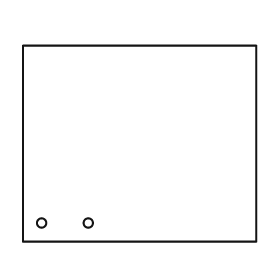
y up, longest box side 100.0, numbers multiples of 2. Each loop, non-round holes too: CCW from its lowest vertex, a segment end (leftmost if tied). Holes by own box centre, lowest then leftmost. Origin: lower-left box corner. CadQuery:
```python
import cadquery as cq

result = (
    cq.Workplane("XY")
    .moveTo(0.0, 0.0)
    .lineTo(100.0, 0.0)
    .lineTo(100.0, 84.0)
    .lineTo(0.0, 84.0)
    .close()
    .moveTo(8.0, 8.0)
    .circle(2.0)
    .moveTo(28.0, 8.0)
    .circle(2.0)
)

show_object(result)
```